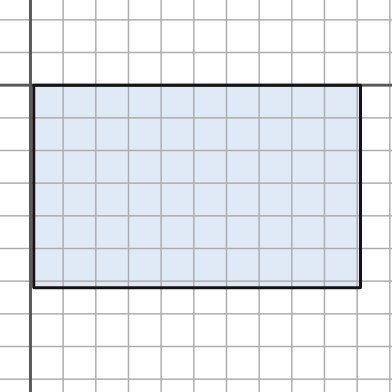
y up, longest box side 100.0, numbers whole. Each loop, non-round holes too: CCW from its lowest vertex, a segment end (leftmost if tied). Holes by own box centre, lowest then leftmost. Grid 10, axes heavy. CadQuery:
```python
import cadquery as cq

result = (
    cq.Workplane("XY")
    .moveTo(1.0, -62.0)
    .lineTo(101.0, -62.0)
    .lineTo(101.0, 0.0)
    .lineTo(1.0, 0.0)
    .close()
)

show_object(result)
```